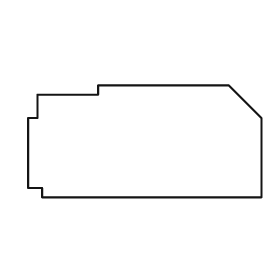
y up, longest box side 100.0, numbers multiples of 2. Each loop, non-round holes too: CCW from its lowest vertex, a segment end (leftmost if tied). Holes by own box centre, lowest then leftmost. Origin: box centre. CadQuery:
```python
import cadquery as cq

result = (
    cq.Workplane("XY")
    .moveTo(-44.0, -24.0)
    .lineTo(50.0, -24.0)
    .lineTo(50.0, 10.0)
    .lineTo(36.0, 24.0)
    .lineTo(-20.0, 24.0)
    .lineTo(-20.0, 20.0)
    .lineTo(-46.0, 20.0)
    .lineTo(-46.0, 10.0)
    .lineTo(-50.0, 10.0)
    .lineTo(-50.0, -20.0)
    .lineTo(-44.0, -20.0)
    .close()
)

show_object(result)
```